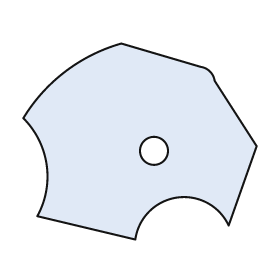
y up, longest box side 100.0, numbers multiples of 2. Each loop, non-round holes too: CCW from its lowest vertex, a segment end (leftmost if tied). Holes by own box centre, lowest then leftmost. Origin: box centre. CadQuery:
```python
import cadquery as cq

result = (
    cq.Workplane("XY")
    .moveTo(-2.0, -42.0)
    .threePointArc((16.0, -24.0), (38.0, -36.0))
    .lineTo(50.0, -2.0)
    .lineTo(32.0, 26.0)
    .threePointArc((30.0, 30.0), (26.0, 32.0))
    .lineTo(-8.0, 42.0)
    .threePointArc((-32.0, 30.0), (-50.0, 10.0))
    .threePointArc((-40.0, -10.0), (-44.0, -32.0))
    .close()
    .moveTo(6.0, -4.0)
    .circle(6.0)
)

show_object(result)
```